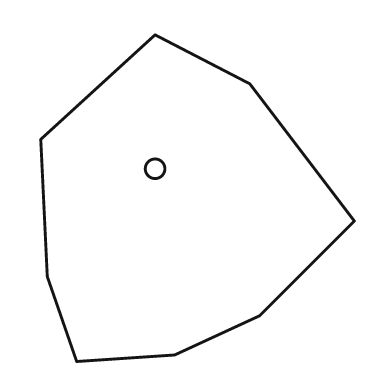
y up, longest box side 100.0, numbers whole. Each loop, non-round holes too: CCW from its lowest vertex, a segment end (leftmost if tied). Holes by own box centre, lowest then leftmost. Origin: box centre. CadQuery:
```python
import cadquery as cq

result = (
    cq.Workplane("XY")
    .moveTo(-37.0, -50.0)
    .lineTo(-7.0, -48.0)
    .lineTo(19.0, -36.0)
    .lineTo(48.0, -7.0)
    .lineTo(16.0, 35.0)
    .lineTo(-13.0, 50.0)
    .lineTo(-48.0, 18.0)
    .lineTo(-46.0, -24.0)
    .close()
    .moveTo(-13.0, 9.0)
    .circle(3.0)
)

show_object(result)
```